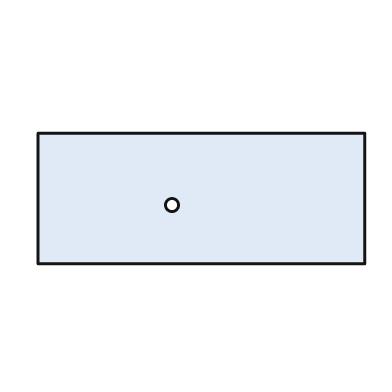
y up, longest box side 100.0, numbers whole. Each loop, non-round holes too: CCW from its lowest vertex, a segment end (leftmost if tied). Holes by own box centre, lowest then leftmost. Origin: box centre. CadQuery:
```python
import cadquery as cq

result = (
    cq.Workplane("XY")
    .moveTo(-50.0, -20.0)
    .lineTo(50.0, -20.0)
    .lineTo(50.0, 20.0)
    .lineTo(-50.0, 20.0)
    .close()
    .moveTo(-9.0, -2.0)
    .circle(2.0)
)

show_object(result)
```